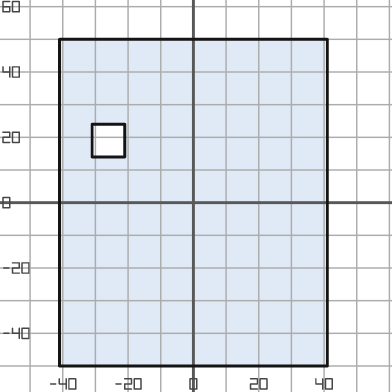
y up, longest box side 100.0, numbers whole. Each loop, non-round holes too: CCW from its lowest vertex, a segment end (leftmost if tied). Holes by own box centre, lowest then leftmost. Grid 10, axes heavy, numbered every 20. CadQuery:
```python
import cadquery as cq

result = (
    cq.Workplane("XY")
    .moveTo(-41.0, -50.0)
    .lineTo(41.0, -50.0)
    .lineTo(41.0, 50.0)
    .lineTo(-41.0, 50.0)
    .close()
    .moveTo(-31.0, 14.0)
    .lineTo(-21.0, 14.0)
    .lineTo(-21.0, 24.0)
    .lineTo(-31.0, 24.0)
    .close()
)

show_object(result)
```